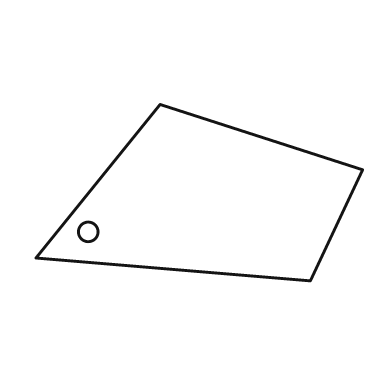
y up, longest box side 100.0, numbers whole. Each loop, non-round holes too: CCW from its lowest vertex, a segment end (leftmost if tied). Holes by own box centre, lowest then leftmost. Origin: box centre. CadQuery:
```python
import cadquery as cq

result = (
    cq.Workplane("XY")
    .moveTo(34.0, -27.0)
    .lineTo(50.0, 7.0)
    .lineTo(-12.0, 27.0)
    .lineTo(-50.0, -20.0)
    .close()
    .moveTo(-34.0, -12.0)
    .circle(3.0)
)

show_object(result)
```